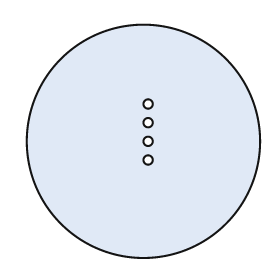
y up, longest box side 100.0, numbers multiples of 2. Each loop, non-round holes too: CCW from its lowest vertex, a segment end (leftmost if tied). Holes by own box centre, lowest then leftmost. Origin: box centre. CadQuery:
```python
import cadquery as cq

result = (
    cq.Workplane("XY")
    .moveTo(0.0, 0.0)
    .circle(50.0)
    .moveTo(2.0, -8.0)
    .circle(2.0)
    .moveTo(2.0, 0.0)
    .circle(2.0)
    .moveTo(2.0, 8.0)
    .circle(2.0)
    .moveTo(2.0, 16.0)
    .circle(2.0)
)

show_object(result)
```